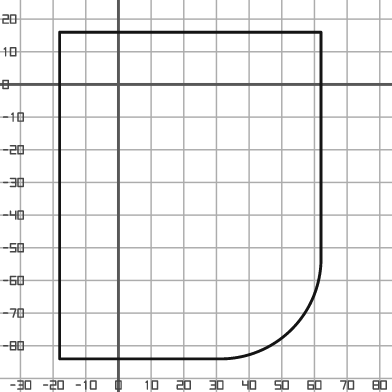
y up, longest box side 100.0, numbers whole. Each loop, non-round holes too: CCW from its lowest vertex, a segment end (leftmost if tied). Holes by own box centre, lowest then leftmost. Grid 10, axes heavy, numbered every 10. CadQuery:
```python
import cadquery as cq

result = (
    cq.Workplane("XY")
    .moveTo(-18.0, -84.0)
    .lineTo(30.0, -84.0)
    .threePointArc((53.0, -75.0), (62.0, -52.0))
    .lineTo(62.0, 16.0)
    .lineTo(-18.0, 16.0)
    .close()
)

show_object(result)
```